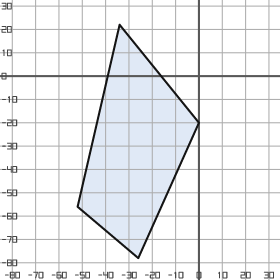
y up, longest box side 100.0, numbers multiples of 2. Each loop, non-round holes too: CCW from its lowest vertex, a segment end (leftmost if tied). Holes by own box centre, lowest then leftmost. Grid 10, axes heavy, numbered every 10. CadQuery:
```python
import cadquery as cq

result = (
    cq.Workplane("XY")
    .moveTo(-26.0, -78.0)
    .lineTo(0.0, -20.0)
    .lineTo(-34.0, 22.0)
    .lineTo(-52.0, -56.0)
    .close()
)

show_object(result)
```